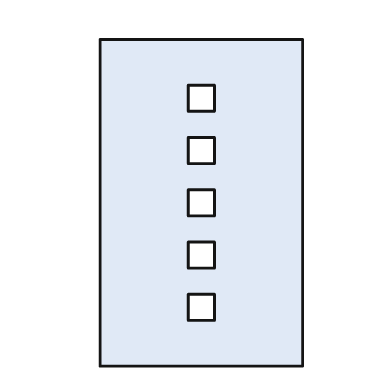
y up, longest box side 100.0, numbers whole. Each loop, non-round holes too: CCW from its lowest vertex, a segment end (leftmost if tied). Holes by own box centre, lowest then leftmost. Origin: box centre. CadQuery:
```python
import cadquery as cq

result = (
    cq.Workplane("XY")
    .moveTo(-31.0, -50.0)
    .lineTo(31.0, -50.0)
    .lineTo(31.0, 50.0)
    .lineTo(-31.0, 50.0)
    .close()
    .moveTo(-4.0, -36.0)
    .lineTo(4.0, -36.0)
    .lineTo(4.0, -28.0)
    .lineTo(-4.0, -28.0)
    .close()
    .moveTo(-4.0, -20.0)
    .lineTo(4.0, -20.0)
    .lineTo(4.0, -12.0)
    .lineTo(-4.0, -12.0)
    .close()
    .moveTo(-4.0, -4.0)
    .lineTo(4.0, -4.0)
    .lineTo(4.0, 4.0)
    .lineTo(-4.0, 4.0)
    .close()
    .moveTo(-4.0, 12.0)
    .lineTo(4.0, 12.0)
    .lineTo(4.0, 20.0)
    .lineTo(-4.0, 20.0)
    .close()
    .moveTo(-4.0, 28.0)
    .lineTo(4.0, 28.0)
    .lineTo(4.0, 36.0)
    .lineTo(-4.0, 36.0)
    .close()
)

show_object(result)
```